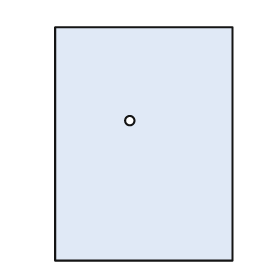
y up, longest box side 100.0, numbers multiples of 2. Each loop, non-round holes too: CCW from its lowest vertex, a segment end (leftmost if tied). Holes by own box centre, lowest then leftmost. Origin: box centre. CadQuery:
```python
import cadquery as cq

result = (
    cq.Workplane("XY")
    .moveTo(-38.0, -50.0)
    .lineTo(38.0, -50.0)
    .lineTo(38.0, 50.0)
    .lineTo(-38.0, 50.0)
    .close()
    .moveTo(-6.0, 10.0)
    .circle(2.0)
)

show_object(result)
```